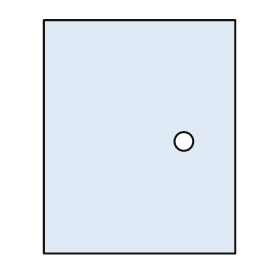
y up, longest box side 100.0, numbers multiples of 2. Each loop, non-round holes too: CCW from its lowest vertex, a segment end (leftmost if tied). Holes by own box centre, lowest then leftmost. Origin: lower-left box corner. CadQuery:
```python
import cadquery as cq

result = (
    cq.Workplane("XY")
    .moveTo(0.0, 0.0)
    .lineTo(82.0, 0.0)
    .lineTo(82.0, 100.0)
    .lineTo(0.0, 100.0)
    .close()
    .moveTo(60.0, 48.0)
    .circle(4.0)
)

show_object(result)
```